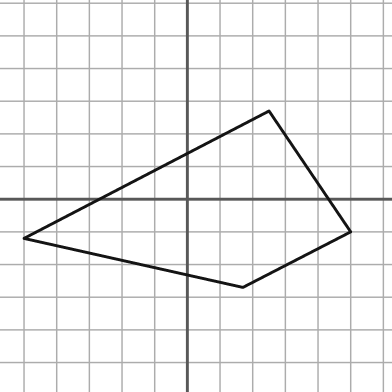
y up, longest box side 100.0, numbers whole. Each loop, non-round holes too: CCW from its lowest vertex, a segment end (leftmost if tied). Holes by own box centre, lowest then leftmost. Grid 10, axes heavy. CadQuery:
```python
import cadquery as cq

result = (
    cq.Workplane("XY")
    .moveTo(17.0, -27.0)
    .lineTo(50.0, -10.0)
    .lineTo(25.0, 27.0)
    .lineTo(-50.0, -12.0)
    .close()
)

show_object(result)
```